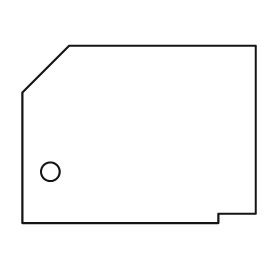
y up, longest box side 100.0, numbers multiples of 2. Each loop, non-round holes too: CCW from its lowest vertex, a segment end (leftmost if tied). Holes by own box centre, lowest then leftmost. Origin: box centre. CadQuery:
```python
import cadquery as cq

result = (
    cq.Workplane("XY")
    .moveTo(-50.0, -38.0)
    .lineTo(34.0, -38.0)
    .lineTo(34.0, -34.0)
    .lineTo(50.0, -34.0)
    .lineTo(50.0, 38.0)
    .lineTo(-30.0, 38.0)
    .lineTo(-50.0, 18.0)
    .close()
    .moveTo(-38.0, -16.0)
    .circle(4.0)
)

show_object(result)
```